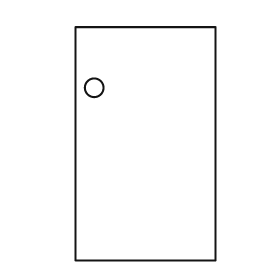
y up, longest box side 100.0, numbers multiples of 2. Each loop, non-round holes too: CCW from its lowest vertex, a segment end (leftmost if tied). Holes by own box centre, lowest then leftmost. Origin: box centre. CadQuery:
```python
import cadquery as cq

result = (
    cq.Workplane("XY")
    .moveTo(-30.0, -50.0)
    .lineTo(30.0, -50.0)
    .lineTo(30.0, 50.0)
    .lineTo(-30.0, 50.0)
    .close()
    .moveTo(-22.0, 24.0)
    .circle(4.0)
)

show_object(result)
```